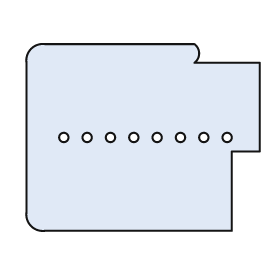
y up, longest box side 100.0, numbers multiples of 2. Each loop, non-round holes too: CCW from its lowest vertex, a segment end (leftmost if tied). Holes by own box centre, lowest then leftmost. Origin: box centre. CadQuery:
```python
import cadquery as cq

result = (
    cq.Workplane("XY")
    .moveTo(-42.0, -40.0)
    .lineTo(38.0, -40.0)
    .lineTo(38.0, -6.0)
    .lineTo(50.0, -6.0)
    .lineTo(50.0, 32.0)
    .lineTo(22.0, 32.0)
    .threePointArc((24.0, 36.0), (22.0, 40.0))
    .lineTo(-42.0, 40.0)
    .threePointArc((-48.0, 38.0), (-50.0, 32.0))
    .lineTo(-50.0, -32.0)
    .threePointArc((-48.0, -38.0), (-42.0, -40.0))
    .close()
    .moveTo(-34.0, 0.0)
    .circle(2.0)
    .moveTo(-24.0, 0.0)
    .circle(2.0)
    .moveTo(-14.0, 0.0)
    .circle(2.0)
    .moveTo(-4.0, 0.0)
    .circle(2.0)
    .moveTo(6.0, 0.0)
    .circle(2.0)
    .moveTo(16.0, 0.0)
    .circle(2.0)
    .moveTo(26.0, 0.0)
    .circle(2.0)
    .moveTo(36.0, 0.0)
    .circle(2.0)
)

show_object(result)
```